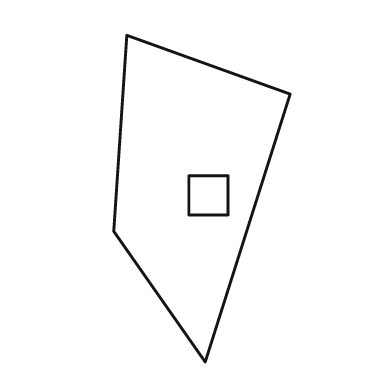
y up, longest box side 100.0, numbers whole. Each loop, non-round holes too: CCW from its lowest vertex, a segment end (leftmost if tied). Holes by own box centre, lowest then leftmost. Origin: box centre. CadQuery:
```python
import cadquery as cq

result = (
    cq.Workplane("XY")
    .moveTo(1.0, -50.0)
    .lineTo(27.0, 32.0)
    .lineTo(-23.0, 50.0)
    .lineTo(-27.0, -10.0)
    .close()
    .moveTo(-4.0, -5.0)
    .lineTo(8.0, -5.0)
    .lineTo(8.0, 7.0)
    .lineTo(-4.0, 7.0)
    .close()
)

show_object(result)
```